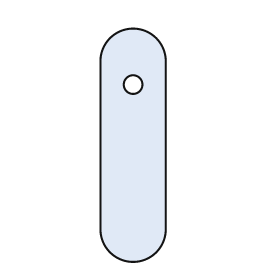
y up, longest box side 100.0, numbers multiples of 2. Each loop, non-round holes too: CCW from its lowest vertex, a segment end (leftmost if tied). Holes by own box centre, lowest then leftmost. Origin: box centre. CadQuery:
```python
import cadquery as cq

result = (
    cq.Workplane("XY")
    .moveTo(-14.0, -36.0)
    .threePointArc((0.0, -50.0), (14.0, -36.0))
    .lineTo(14.0, 36.0)
    .threePointArc((0.0, 50.0), (-14.0, 36.0))
    .close()
    .moveTo(0.0, 26.0)
    .circle(4.0)
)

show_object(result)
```